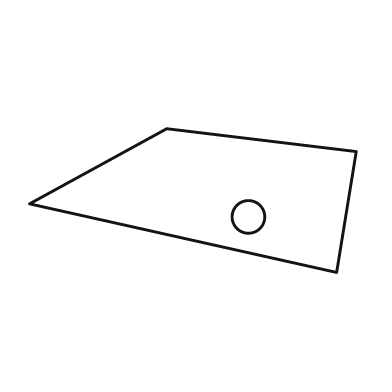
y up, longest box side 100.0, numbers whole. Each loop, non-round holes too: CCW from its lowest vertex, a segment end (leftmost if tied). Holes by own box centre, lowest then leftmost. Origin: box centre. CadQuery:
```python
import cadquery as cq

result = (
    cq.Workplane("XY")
    .moveTo(44.0, -22.0)
    .lineTo(50.0, 15.0)
    .lineTo(-8.0, 22.0)
    .lineTo(-50.0, -1.0)
    .close()
    .moveTo(17.0, -5.0)
    .circle(5.0)
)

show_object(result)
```